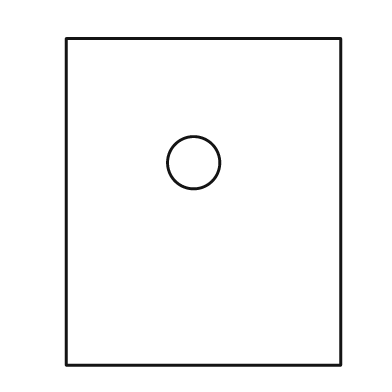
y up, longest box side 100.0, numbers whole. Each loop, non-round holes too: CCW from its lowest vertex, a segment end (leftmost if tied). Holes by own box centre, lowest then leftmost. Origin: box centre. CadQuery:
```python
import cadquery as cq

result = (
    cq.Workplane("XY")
    .moveTo(-42.0, -50.0)
    .lineTo(42.0, -50.0)
    .lineTo(42.0, 50.0)
    .lineTo(-42.0, 50.0)
    .close()
    .moveTo(-3.0, 12.0)
    .circle(8.0)
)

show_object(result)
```